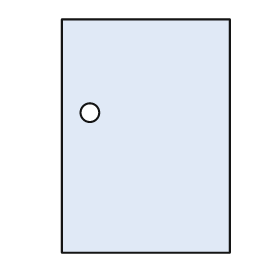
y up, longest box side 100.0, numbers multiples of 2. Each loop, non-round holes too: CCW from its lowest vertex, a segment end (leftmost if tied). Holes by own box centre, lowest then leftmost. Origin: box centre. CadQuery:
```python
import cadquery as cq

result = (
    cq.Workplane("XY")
    .moveTo(-36.0, -50.0)
    .lineTo(36.0, -50.0)
    .lineTo(36.0, 50.0)
    .lineTo(-36.0, 50.0)
    .close()
    .moveTo(-24.0, 10.0)
    .circle(4.0)
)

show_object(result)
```